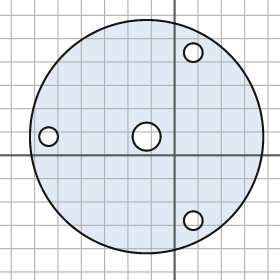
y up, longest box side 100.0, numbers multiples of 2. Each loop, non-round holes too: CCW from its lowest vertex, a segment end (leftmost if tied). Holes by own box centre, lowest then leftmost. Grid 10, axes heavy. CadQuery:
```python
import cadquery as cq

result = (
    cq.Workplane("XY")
    .moveTo(-12.0, 8.0)
    .circle(50.0)
    .moveTo(8.0, -28.0)
    .circle(4.0)
    .moveTo(-54.0, 8.0)
    .circle(4.0)
    .moveTo(-12.0, 8.0)
    .circle(6.0)
    .moveTo(8.0, 44.0)
    .circle(4.0)
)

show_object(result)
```